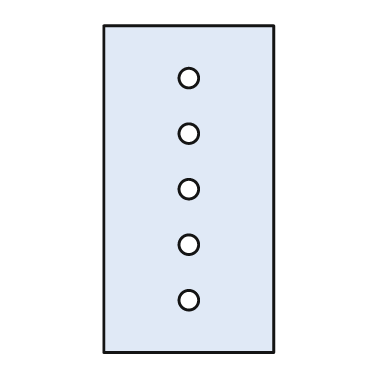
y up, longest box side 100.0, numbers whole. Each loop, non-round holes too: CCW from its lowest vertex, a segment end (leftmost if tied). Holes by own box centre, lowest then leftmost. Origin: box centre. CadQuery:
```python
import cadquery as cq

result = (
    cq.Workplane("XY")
    .moveTo(-26.0, -50.0)
    .lineTo(26.0, -50.0)
    .lineTo(26.0, 50.0)
    .lineTo(-26.0, 50.0)
    .close()
    .moveTo(0.0, -34.0)
    .circle(3.0)
    .moveTo(0.0, -17.0)
    .circle(3.0)
    .moveTo(0.0, 0.0)
    .circle(3.0)
    .moveTo(0.0, 17.0)
    .circle(3.0)
    .moveTo(0.0, 34.0)
    .circle(3.0)
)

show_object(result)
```